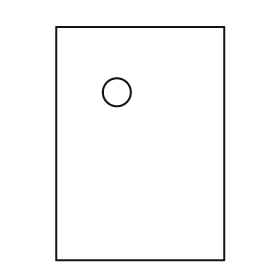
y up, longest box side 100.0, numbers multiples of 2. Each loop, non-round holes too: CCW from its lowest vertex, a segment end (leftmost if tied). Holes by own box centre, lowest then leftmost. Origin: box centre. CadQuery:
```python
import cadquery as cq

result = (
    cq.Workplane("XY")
    .moveTo(-36.0, -50.0)
    .lineTo(36.0, -50.0)
    .lineTo(36.0, 50.0)
    .lineTo(-36.0, 50.0)
    .close()
    .moveTo(-10.0, 22.0)
    .circle(6.0)
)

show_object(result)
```